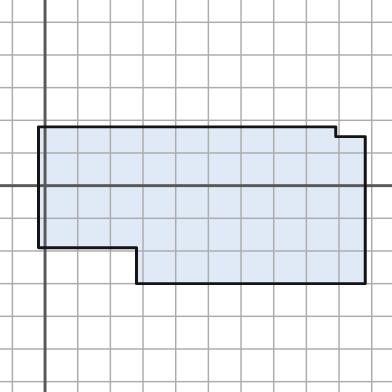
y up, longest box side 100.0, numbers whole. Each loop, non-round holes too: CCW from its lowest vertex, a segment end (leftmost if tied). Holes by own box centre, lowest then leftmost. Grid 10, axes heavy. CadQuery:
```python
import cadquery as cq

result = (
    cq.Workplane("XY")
    .moveTo(28.0, -30.0)
    .lineTo(98.0, -30.0)
    .lineTo(98.0, 15.0)
    .lineTo(89.0, 15.0)
    .lineTo(89.0, 18.0)
    .lineTo(-2.0, 18.0)
    .lineTo(-2.0, -19.0)
    .lineTo(28.0, -19.0)
    .close()
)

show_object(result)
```